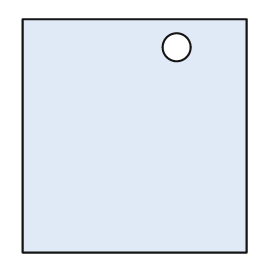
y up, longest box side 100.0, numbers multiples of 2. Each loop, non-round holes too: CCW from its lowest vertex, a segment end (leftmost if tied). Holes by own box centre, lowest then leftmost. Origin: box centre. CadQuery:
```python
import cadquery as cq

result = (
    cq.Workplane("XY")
    .moveTo(-48.0, -50.0)
    .lineTo(48.0, -50.0)
    .lineTo(48.0, 50.0)
    .lineTo(-48.0, 50.0)
    .close()
    .moveTo(18.0, 38.0)
    .circle(6.0)
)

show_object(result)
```